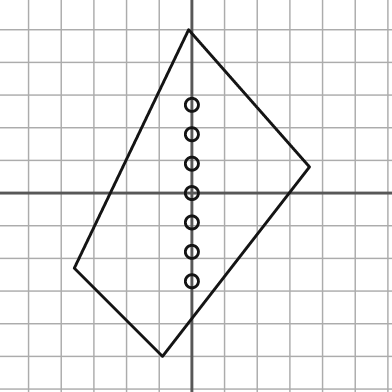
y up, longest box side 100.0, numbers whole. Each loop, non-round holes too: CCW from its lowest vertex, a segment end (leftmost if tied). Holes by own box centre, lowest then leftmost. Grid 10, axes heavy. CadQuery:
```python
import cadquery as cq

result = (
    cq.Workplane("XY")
    .moveTo(-9.0, -50.0)
    .lineTo(36.0, 8.0)
    .lineTo(-1.0, 50.0)
    .lineTo(-36.0, -23.0)
    .close()
    .moveTo(0.0, -27.0)
    .circle(2.0)
    .moveTo(0.0, -18.0)
    .circle(2.0)
    .moveTo(0.0, -9.0)
    .circle(2.0)
    .moveTo(0.0, 0.0)
    .circle(2.0)
    .moveTo(0.0, 9.0)
    .circle(2.0)
    .moveTo(0.0, 18.0)
    .circle(2.0)
    .moveTo(0.0, 27.0)
    .circle(2.0)
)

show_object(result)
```